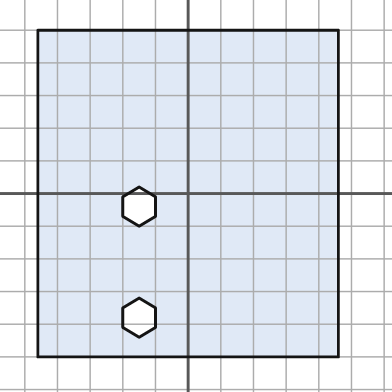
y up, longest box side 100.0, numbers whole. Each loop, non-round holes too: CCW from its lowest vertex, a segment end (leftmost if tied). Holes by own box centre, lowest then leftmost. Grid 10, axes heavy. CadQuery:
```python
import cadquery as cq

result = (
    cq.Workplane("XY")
    .moveTo(-46.0, -50.0)
    .lineTo(46.0, -50.0)
    .lineTo(46.0, 50.0)
    .lineTo(-46.0, 50.0)
    .close()
    .moveTo(-15.0, -44.0)
    .lineTo(-10.0, -41.0)
    .lineTo(-10.0, -35.0)
    .lineTo(-15.0, -32.0)
    .lineTo(-20.0, -35.0)
    .lineTo(-20.0, -41.0)
    .close()
    .moveTo(-15.0, -10.0)
    .lineTo(-10.0, -7.0)
    .lineTo(-10.0, -1.0)
    .lineTo(-15.0, 2.0)
    .lineTo(-20.0, -1.0)
    .lineTo(-20.0, -7.0)
    .close()
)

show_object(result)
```